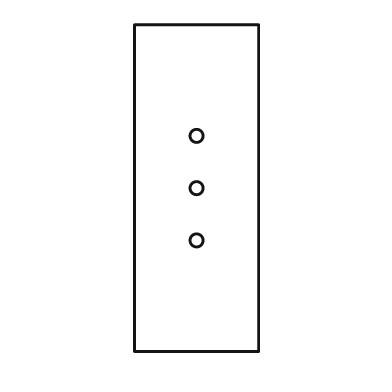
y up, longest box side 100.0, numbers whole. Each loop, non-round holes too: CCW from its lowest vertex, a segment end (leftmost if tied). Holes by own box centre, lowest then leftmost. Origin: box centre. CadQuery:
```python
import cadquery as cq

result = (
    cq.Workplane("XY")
    .moveTo(-19.0, -50.0)
    .lineTo(19.0, -50.0)
    .lineTo(19.0, 50.0)
    .lineTo(-19.0, 50.0)
    .close()
    .moveTo(0.0, -16.0)
    .circle(2.0)
    .moveTo(0.0, 0.0)
    .circle(2.0)
    .moveTo(0.0, 16.0)
    .circle(2.0)
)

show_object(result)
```